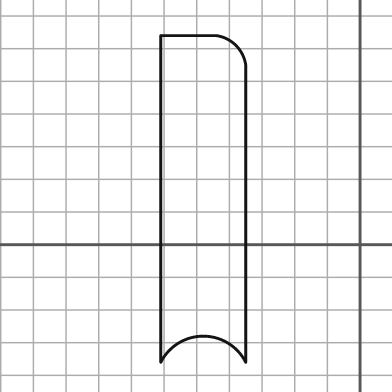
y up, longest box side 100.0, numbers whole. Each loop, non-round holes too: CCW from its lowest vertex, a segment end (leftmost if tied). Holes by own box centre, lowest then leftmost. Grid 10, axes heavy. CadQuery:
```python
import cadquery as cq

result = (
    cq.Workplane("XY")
    .moveTo(-61.0, -36.0)
    .threePointArc((-48.0, -28.0), (-35.0, -36.0))
    .lineTo(-35.0, 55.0)
    .threePointArc((-38.0, 61.0), (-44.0, 64.0))
    .lineTo(-61.0, 64.0)
    .close()
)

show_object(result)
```